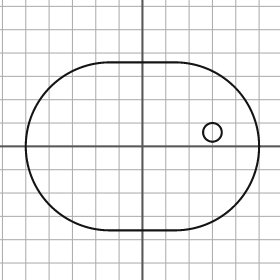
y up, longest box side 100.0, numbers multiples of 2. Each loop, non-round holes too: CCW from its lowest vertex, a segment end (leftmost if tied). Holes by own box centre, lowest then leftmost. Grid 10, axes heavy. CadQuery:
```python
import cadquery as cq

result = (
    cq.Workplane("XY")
    .moveTo(-14.0, -36.0)
    .lineTo(14.0, -36.0)
    .threePointArc((50.0, 0.0), (14.0, 36.0))
    .lineTo(-14.0, 36.0)
    .threePointArc((-50.0, 0.0), (-14.0, -36.0))
    .close()
    .moveTo(30.0, 6.0)
    .circle(4.0)
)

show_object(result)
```